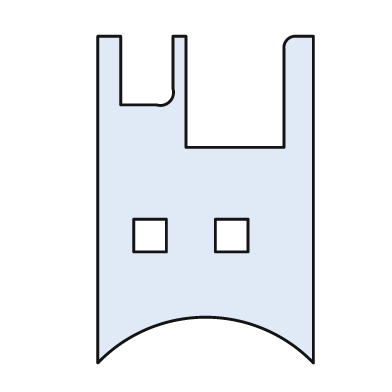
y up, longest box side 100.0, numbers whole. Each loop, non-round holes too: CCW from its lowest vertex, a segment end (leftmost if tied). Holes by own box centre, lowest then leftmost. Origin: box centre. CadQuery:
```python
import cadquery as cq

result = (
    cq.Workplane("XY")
    .moveTo(-33.0, -50.0)
    .threePointArc((0.0, -36.0), (33.0, -50.0))
    .lineTo(33.0, 50.0)
    .lineTo(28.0, 50.0)
    .threePointArc((25.0, 49.0), (24.0, 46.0))
    .lineTo(24.0, 16.0)
    .lineTo(-6.0, 16.0)
    .lineTo(-6.0, 50.0)
    .lineTo(-10.0, 50.0)
    .lineTo(-10.0, 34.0)
    .threePointArc((-11.0, 30.0), (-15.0, 29.0))
    .lineTo(-26.0, 29.0)
    .lineTo(-26.0, 50.0)
    .lineTo(-33.0, 50.0)
    .close()
    .moveTo(-22.0, -16.0)
    .lineTo(-12.0, -16.0)
    .lineTo(-12.0, -6.0)
    .lineTo(-22.0, -6.0)
    .close()
    .moveTo(3.0, -16.0)
    .lineTo(13.0, -16.0)
    .lineTo(13.0, -6.0)
    .lineTo(3.0, -6.0)
    .close()
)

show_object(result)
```